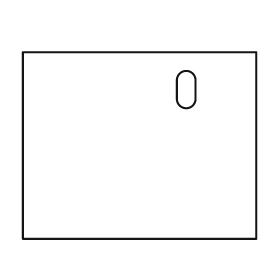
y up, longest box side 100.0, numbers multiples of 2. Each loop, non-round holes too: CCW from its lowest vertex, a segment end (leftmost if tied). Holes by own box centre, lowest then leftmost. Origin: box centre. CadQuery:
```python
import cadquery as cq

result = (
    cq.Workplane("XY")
    .moveTo(-50.0, -40.0)
    .lineTo(50.0, -40.0)
    .lineTo(50.0, 40.0)
    .lineTo(-50.0, 40.0)
    .close()
    .moveTo(16.0, 20.0)
    .threePointArc((20.0, 16.0), (24.0, 20.0))
    .lineTo(24.0, 28.0)
    .threePointArc((20.0, 32.0), (16.0, 28.0))
    .close()
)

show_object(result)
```